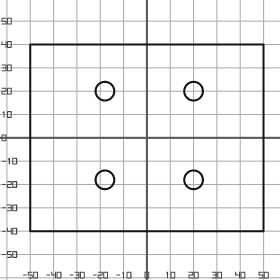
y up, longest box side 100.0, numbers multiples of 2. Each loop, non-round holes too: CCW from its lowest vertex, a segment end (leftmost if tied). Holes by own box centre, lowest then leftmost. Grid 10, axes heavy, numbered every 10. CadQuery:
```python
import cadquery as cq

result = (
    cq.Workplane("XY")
    .moveTo(-50.0, -40.0)
    .lineTo(50.0, -40.0)
    .lineTo(50.0, 40.0)
    .lineTo(-50.0, 40.0)
    .close()
    .moveTo(-18.0, -18.0)
    .circle(4.0)
    .moveTo(20.0, -18.0)
    .circle(4.0)
    .moveTo(-18.0, 20.0)
    .circle(4.0)
    .moveTo(20.0, 20.0)
    .circle(4.0)
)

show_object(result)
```